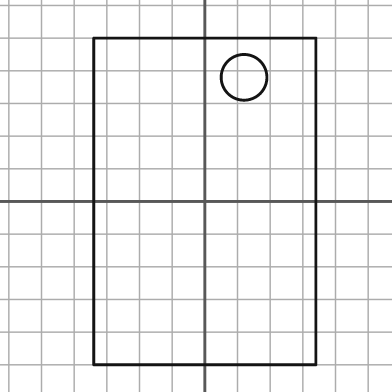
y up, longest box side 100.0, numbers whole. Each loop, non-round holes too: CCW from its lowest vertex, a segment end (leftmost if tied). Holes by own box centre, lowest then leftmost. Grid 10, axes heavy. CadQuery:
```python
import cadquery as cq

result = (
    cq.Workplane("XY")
    .moveTo(-34.0, -50.0)
    .lineTo(34.0, -50.0)
    .lineTo(34.0, 50.0)
    .lineTo(-34.0, 50.0)
    .close()
    .moveTo(12.0, 38.0)
    .circle(7.0)
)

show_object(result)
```